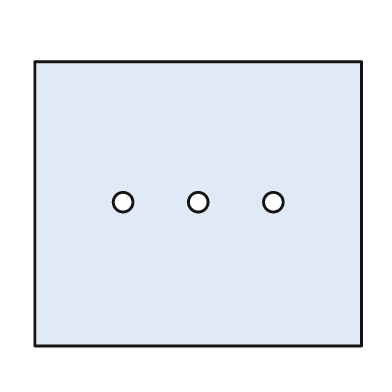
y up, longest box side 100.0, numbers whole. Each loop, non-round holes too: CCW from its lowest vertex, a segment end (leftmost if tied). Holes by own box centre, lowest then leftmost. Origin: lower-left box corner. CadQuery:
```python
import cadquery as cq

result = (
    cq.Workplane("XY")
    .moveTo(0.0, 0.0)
    .lineTo(100.0, 0.0)
    .lineTo(100.0, 87.0)
    .lineTo(0.0, 87.0)
    .close()
    .moveTo(27.0, 44.0)
    .circle(3.0)
    .moveTo(50.0, 44.0)
    .circle(3.0)
    .moveTo(73.0, 44.0)
    .circle(3.0)
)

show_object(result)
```